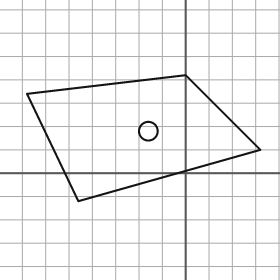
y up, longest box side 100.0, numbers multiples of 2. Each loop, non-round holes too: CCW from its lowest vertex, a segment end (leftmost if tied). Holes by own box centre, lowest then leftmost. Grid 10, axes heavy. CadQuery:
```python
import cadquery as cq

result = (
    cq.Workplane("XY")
    .moveTo(-46.0, -12.0)
    .lineTo(32.0, 10.0)
    .lineTo(0.0, 42.0)
    .lineTo(-68.0, 34.0)
    .close()
    .moveTo(-16.0, 18.0)
    .circle(4.0)
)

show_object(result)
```